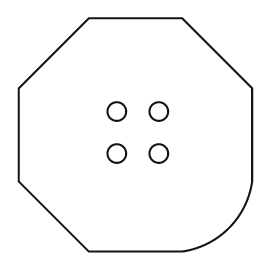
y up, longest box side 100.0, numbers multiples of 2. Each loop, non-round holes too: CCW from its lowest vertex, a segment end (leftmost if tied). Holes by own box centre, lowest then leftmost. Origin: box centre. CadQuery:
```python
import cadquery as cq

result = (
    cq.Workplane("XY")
    .moveTo(-20.0, -50.0)
    .lineTo(20.0, -50.0)
    .threePointArc((40.0, -40.0), (50.0, -20.0))
    .lineTo(50.0, 20.0)
    .lineTo(20.0, 50.0)
    .lineTo(-20.0, 50.0)
    .lineTo(-50.0, 20.0)
    .lineTo(-50.0, -20.0)
    .close()
    .moveTo(-8.0, -8.0)
    .circle(4.0)
    .moveTo(10.0, -8.0)
    .circle(4.0)
    .moveTo(-8.0, 10.0)
    .circle(4.0)
    .moveTo(10.0, 10.0)
    .circle(4.0)
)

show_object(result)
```